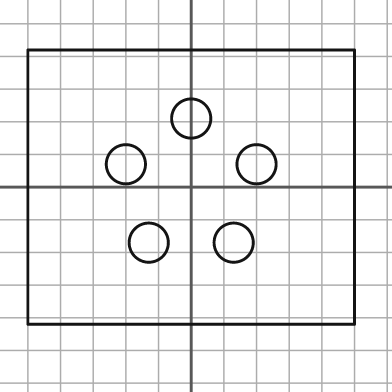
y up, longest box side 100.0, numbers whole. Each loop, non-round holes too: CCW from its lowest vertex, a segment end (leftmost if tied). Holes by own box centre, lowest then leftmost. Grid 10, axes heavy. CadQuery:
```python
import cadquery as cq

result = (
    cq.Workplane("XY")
    .moveTo(-50.0, -42.0)
    .lineTo(50.0, -42.0)
    .lineTo(50.0, 42.0)
    .lineTo(-50.0, 42.0)
    .close()
    .moveTo(-13.0, -17.0)
    .circle(6.0)
    .moveTo(13.0, -17.0)
    .circle(6.0)
    .moveTo(-20.0, 7.0)
    .circle(6.0)
    .moveTo(20.0, 7.0)
    .circle(6.0)
    .moveTo(0.0, 21.0)
    .circle(6.0)
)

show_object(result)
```